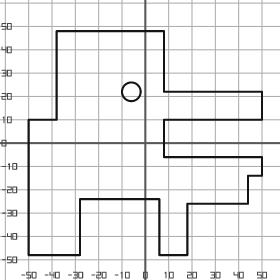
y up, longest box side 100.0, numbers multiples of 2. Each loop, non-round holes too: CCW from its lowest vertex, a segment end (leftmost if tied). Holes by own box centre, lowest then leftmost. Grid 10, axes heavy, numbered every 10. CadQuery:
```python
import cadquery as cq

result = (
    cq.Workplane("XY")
    .moveTo(-50.0, -48.0)
    .lineTo(-28.0, -48.0)
    .lineTo(-28.0, -24.0)
    .lineTo(6.0, -24.0)
    .lineTo(6.0, -48.0)
    .lineTo(18.0, -48.0)
    .lineTo(18.0, -26.0)
    .lineTo(44.0, -26.0)
    .lineTo(44.0, -14.0)
    .lineTo(50.0, -14.0)
    .lineTo(50.0, -6.0)
    .lineTo(8.0, -6.0)
    .lineTo(8.0, 10.0)
    .lineTo(50.0, 10.0)
    .lineTo(50.0, 22.0)
    .lineTo(8.0, 22.0)
    .lineTo(8.0, 48.0)
    .lineTo(-38.0, 48.0)
    .lineTo(-38.0, 10.0)
    .lineTo(-50.0, 10.0)
    .close()
    .moveTo(-6.0, 22.0)
    .circle(4.0)
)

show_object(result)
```